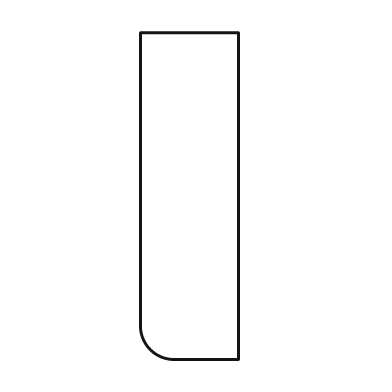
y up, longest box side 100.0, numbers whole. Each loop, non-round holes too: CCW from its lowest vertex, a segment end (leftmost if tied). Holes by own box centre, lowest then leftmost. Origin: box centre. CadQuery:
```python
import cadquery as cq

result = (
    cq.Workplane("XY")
    .moveTo(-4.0, -50.0)
    .lineTo(15.0, -50.0)
    .lineTo(15.0, 50.0)
    .lineTo(-15.0, 50.0)
    .lineTo(-15.0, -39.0)
    .threePointArc((-12.0, -47.0), (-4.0, -50.0))
    .close()
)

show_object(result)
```